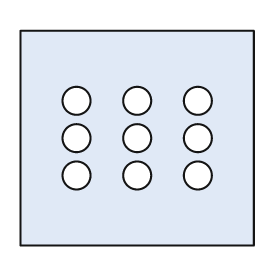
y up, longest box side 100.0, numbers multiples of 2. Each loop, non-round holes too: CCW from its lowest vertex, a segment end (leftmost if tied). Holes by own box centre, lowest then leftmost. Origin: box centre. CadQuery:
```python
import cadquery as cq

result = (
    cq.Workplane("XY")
    .moveTo(-50.0, -46.0)
    .lineTo(50.0, -46.0)
    .lineTo(50.0, 46.0)
    .lineTo(-50.0, 46.0)
    .close()
    .moveTo(-26.0, -16.0)
    .circle(6.0)
    .moveTo(0.0, -16.0)
    .circle(6.0)
    .moveTo(26.0, -16.0)
    .circle(6.0)
    .moveTo(-26.0, 0.0)
    .circle(6.0)
    .moveTo(0.0, 0.0)
    .circle(6.0)
    .moveTo(26.0, 0.0)
    .circle(6.0)
    .moveTo(-26.0, 16.0)
    .circle(6.0)
    .moveTo(0.0, 16.0)
    .circle(6.0)
    .moveTo(26.0, 16.0)
    .circle(6.0)
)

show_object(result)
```